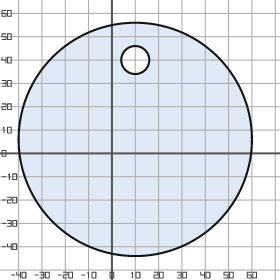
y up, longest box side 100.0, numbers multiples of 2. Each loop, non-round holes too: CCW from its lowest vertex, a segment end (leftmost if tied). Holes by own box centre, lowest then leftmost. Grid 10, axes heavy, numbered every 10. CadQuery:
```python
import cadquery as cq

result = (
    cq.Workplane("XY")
    .moveTo(10.0, 6.0)
    .circle(50.0)
    .moveTo(10.0, 40.0)
    .circle(6.0)
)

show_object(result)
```